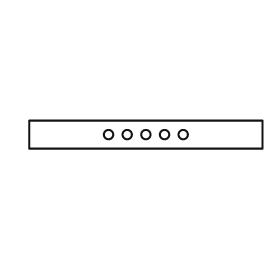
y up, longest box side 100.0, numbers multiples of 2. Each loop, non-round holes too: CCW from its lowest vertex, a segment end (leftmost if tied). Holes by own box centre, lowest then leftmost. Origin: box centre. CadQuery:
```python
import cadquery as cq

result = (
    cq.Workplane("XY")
    .moveTo(-50.0, -6.0)
    .lineTo(50.0, -6.0)
    .lineTo(50.0, 6.0)
    .lineTo(-50.0, 6.0)
    .close()
    .moveTo(-16.0, 0.0)
    .circle(2.0)
    .moveTo(-8.0, 0.0)
    .circle(2.0)
    .moveTo(0.0, 0.0)
    .circle(2.0)
    .moveTo(8.0, 0.0)
    .circle(2.0)
    .moveTo(16.0, 0.0)
    .circle(2.0)
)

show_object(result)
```